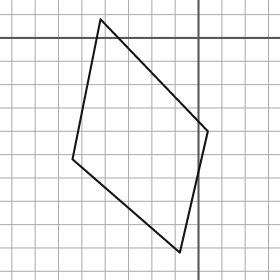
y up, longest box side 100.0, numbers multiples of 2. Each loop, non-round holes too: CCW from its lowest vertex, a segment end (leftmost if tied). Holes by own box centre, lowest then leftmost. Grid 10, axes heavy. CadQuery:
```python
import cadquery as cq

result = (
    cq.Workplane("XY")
    .moveTo(-8.0, -92.0)
    .lineTo(4.0, -40.0)
    .lineTo(-42.0, 8.0)
    .lineTo(-54.0, -52.0)
    .close()
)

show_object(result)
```